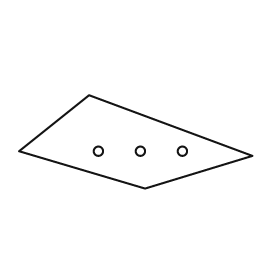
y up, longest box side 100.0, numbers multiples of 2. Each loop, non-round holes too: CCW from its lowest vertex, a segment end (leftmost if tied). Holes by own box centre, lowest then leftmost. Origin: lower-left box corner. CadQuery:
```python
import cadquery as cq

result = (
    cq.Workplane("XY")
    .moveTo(54.0, 0.0)
    .lineTo(100.0, 14.0)
    .lineTo(30.0, 40.0)
    .lineTo(0.0, 16.0)
    .close()
    .moveTo(34.0, 16.0)
    .circle(2.0)
    .moveTo(52.0, 16.0)
    .circle(2.0)
    .moveTo(70.0, 16.0)
    .circle(2.0)
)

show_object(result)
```